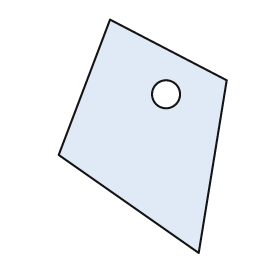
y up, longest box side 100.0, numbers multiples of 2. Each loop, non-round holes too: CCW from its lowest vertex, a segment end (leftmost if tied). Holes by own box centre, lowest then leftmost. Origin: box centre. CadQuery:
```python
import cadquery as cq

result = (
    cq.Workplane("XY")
    .moveTo(24.0, -50.0)
    .lineTo(36.0, 24.0)
    .lineTo(-14.0, 50.0)
    .lineTo(-36.0, -8.0)
    .close()
    .moveTo(10.0, 18.0)
    .circle(6.0)
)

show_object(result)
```